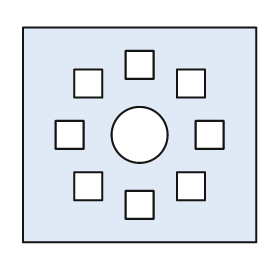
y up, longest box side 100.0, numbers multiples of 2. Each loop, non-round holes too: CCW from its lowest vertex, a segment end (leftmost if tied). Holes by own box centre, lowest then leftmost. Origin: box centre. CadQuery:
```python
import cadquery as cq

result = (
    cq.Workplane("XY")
    .moveTo(-50.0, -46.0)
    .lineTo(50.0, -46.0)
    .lineTo(50.0, 46.0)
    .lineTo(-50.0, 46.0)
    .close()
    .moveTo(-6.0, -36.0)
    .lineTo(6.0, -36.0)
    .lineTo(6.0, -24.0)
    .lineTo(-6.0, -24.0)
    .close()
    .moveTo(-28.0, -28.0)
    .lineTo(-16.0, -28.0)
    .lineTo(-16.0, -16.0)
    .lineTo(-28.0, -16.0)
    .close()
    .moveTo(16.0, -28.0)
    .lineTo(28.0, -28.0)
    .lineTo(28.0, -16.0)
    .lineTo(16.0, -16.0)
    .close()
    .moveTo(-36.0, -6.0)
    .lineTo(-24.0, -6.0)
    .lineTo(-24.0, 6.0)
    .lineTo(-36.0, 6.0)
    .close()
    .moveTo(0.0, 0.0)
    .circle(12.0)
    .moveTo(24.0, -6.0)
    .lineTo(36.0, -6.0)
    .lineTo(36.0, 6.0)
    .lineTo(24.0, 6.0)
    .close()
    .moveTo(-28.0, 16.0)
    .lineTo(-16.0, 16.0)
    .lineTo(-16.0, 28.0)
    .lineTo(-28.0, 28.0)
    .close()
    .moveTo(16.0, 16.0)
    .lineTo(28.0, 16.0)
    .lineTo(28.0, 28.0)
    .lineTo(16.0, 28.0)
    .close()
    .moveTo(-6.0, 24.0)
    .lineTo(6.0, 24.0)
    .lineTo(6.0, 36.0)
    .lineTo(-6.0, 36.0)
    .close()
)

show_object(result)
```